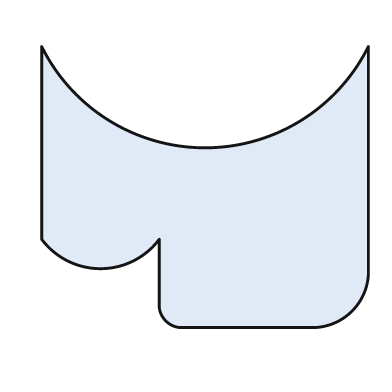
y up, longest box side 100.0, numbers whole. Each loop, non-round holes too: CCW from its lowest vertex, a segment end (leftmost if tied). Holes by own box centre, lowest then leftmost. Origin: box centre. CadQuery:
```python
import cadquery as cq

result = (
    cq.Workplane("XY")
    .moveTo(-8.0, -43.0)
    .lineTo(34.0, -43.0)
    .threePointArc((45.0, -38.0), (50.0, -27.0))
    .lineTo(50.0, 43.0)
    .threePointArc((0.0, 12.0), (-50.0, 43.0))
    .lineTo(-50.0, -16.0)
    .threePointArc((-32.0, -25.0), (-14.0, -16.0))
    .lineTo(-14.0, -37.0)
    .threePointArc((-12.0, -41.0), (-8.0, -43.0))
    .close()
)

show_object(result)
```